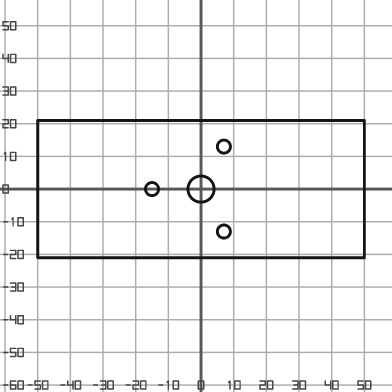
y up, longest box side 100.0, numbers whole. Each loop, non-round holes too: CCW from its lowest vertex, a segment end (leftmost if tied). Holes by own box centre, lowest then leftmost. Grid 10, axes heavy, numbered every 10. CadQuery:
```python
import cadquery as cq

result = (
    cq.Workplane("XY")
    .moveTo(-50.0, -21.0)
    .lineTo(50.0, -21.0)
    .lineTo(50.0, 21.0)
    .lineTo(-50.0, 21.0)
    .close()
    .moveTo(7.0, -13.0)
    .circle(2.0)
    .moveTo(-15.0, 0.0)
    .circle(2.0)
    .moveTo(0.0, 0.0)
    .circle(4.0)
    .moveTo(7.0, 13.0)
    .circle(2.0)
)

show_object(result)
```